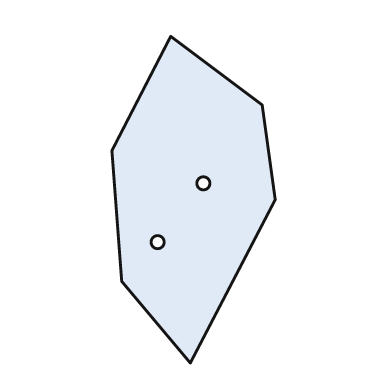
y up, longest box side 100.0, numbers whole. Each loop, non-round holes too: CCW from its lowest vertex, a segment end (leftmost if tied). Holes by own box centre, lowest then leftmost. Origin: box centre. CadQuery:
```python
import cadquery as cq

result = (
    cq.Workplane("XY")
    .moveTo(-1.0, -50.0)
    .lineTo(25.0, 0.0)
    .lineTo(21.0, 29.0)
    .lineTo(-7.0, 50.0)
    .lineTo(-25.0, 15.0)
    .lineTo(-22.0, -25.0)
    .close()
    .moveTo(-11.0, -13.0)
    .circle(2.0)
    .moveTo(3.0, 5.0)
    .circle(2.0)
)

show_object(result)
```